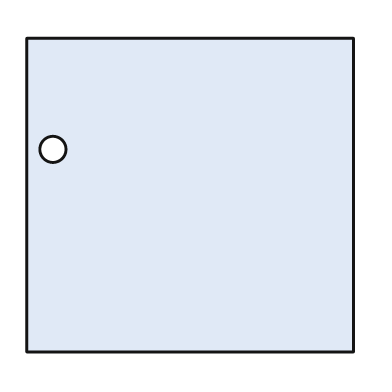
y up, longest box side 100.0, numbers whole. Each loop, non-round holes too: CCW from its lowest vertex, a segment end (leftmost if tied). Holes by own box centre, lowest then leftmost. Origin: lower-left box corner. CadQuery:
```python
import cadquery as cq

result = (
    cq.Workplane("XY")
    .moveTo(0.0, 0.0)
    .lineTo(100.0, 0.0)
    .lineTo(100.0, 96.0)
    .lineTo(0.0, 96.0)
    .close()
    .moveTo(8.0, 62.0)
    .circle(4.0)
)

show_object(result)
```